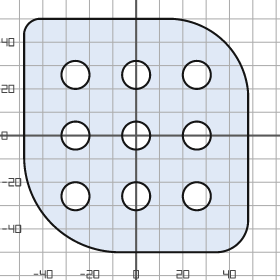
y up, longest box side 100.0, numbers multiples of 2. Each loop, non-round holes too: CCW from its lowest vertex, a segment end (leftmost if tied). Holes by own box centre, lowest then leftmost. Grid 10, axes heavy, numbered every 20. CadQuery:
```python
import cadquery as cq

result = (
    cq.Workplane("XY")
    .moveTo(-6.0, -50.0)
    .lineTo(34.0, -50.0)
    .threePointArc((44.0, -46.0), (48.0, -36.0))
    .lineTo(48.0, 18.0)
    .threePointArc((38.0, 40.0), (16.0, 50.0))
    .lineTo(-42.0, 50.0)
    .threePointArc((-46.0, 48.0), (-48.0, 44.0))
    .lineTo(-48.0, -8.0)
    .threePointArc((-36.0, -38.0), (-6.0, -50.0))
    .close()
    .moveTo(-26.0, -26.0)
    .circle(6.0)
    .moveTo(0.0, -26.0)
    .circle(6.0)
    .moveTo(26.0, -26.0)
    .circle(6.0)
    .moveTo(-26.0, 0.0)
    .circle(6.0)
    .moveTo(0.0, 0.0)
    .circle(6.0)
    .moveTo(26.0, 0.0)
    .circle(6.0)
    .moveTo(-26.0, 26.0)
    .circle(6.0)
    .moveTo(0.0, 26.0)
    .circle(6.0)
    .moveTo(26.0, 26.0)
    .circle(6.0)
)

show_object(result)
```